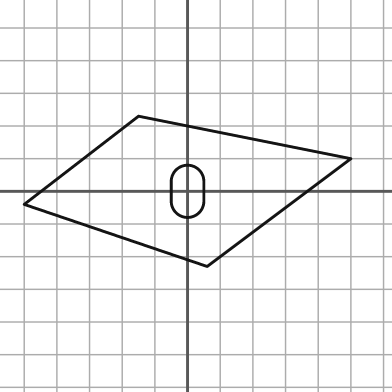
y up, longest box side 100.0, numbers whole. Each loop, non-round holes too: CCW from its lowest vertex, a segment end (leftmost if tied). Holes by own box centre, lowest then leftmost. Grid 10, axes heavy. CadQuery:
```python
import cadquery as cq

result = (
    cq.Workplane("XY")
    .moveTo(6.0, -23.0)
    .lineTo(50.0, 10.0)
    .lineTo(-15.0, 23.0)
    .lineTo(-50.0, -4.0)
    .close()
    .moveTo(-5.0, -3.0)
    .threePointArc((0.0, -8.0), (5.0, -3.0))
    .lineTo(5.0, 3.0)
    .threePointArc((0.0, 8.0), (-5.0, 3.0))
    .close()
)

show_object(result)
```